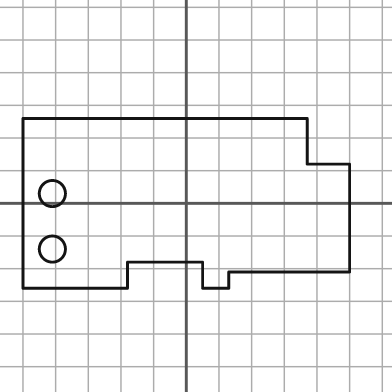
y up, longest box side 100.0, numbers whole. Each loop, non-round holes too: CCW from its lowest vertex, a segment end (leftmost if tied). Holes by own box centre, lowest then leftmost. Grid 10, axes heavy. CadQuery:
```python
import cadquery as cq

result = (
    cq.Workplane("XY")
    .moveTo(-50.0, -26.0)
    .lineTo(-18.0, -26.0)
    .lineTo(-18.0, -18.0)
    .lineTo(5.0, -18.0)
    .lineTo(5.0, -26.0)
    .lineTo(13.0, -26.0)
    .lineTo(13.0, -21.0)
    .lineTo(50.0, -21.0)
    .lineTo(50.0, 12.0)
    .lineTo(37.0, 12.0)
    .lineTo(37.0, 26.0)
    .lineTo(-50.0, 26.0)
    .close()
    .moveTo(-41.0, -14.0)
    .circle(4.0)
    .moveTo(-41.0, 3.0)
    .circle(4.0)
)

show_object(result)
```